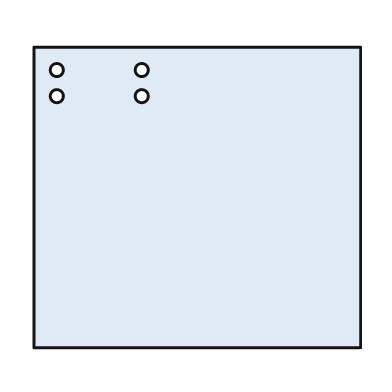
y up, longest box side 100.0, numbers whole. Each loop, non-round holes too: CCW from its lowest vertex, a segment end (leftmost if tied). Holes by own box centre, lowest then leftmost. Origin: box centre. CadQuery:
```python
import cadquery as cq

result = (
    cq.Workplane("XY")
    .moveTo(-50.0, -46.0)
    .lineTo(50.0, -46.0)
    .lineTo(50.0, 46.0)
    .lineTo(-50.0, 46.0)
    .close()
    .moveTo(-43.0, 31.0)
    .circle(2.0)
    .moveTo(-17.0, 31.0)
    .circle(2.0)
    .moveTo(-43.0, 39.0)
    .circle(2.0)
    .moveTo(-17.0, 39.0)
    .circle(2.0)
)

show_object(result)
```